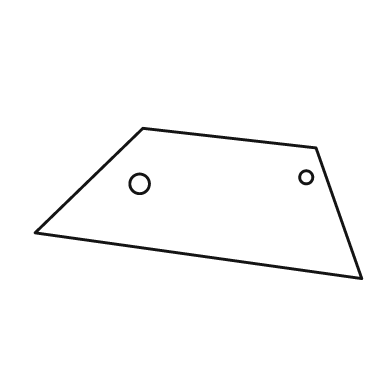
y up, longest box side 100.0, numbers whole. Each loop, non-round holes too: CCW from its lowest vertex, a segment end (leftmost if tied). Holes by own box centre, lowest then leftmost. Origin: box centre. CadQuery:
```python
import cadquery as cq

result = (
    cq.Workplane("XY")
    .moveTo(50.0, -23.0)
    .lineTo(36.0, 17.0)
    .lineTo(-17.0, 23.0)
    .lineTo(-50.0, -9.0)
    .close()
    .moveTo(-18.0, 6.0)
    .circle(3.0)
    .moveTo(33.0, 8.0)
    .circle(2.0)
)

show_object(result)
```